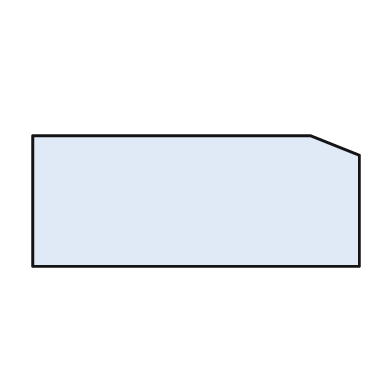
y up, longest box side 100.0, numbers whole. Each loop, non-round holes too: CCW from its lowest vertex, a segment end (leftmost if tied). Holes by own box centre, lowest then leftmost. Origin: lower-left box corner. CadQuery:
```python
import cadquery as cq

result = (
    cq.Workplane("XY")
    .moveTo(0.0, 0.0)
    .lineTo(100.0, 0.0)
    .lineTo(100.0, 34.0)
    .lineTo(85.0, 40.0)
    .lineTo(0.0, 40.0)
    .close()
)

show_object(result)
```